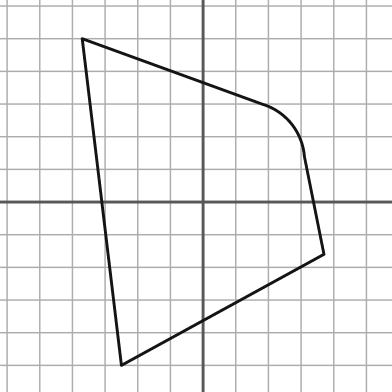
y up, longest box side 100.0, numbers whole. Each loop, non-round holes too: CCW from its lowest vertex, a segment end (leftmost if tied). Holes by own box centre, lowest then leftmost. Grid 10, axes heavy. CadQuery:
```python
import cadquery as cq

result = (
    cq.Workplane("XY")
    .moveTo(-25.0, -50.0)
    .lineTo(37.0, -16.0)
    .lineTo(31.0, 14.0)
    .threePointArc((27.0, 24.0), (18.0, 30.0))
    .lineTo(-37.0, 50.0)
    .close()
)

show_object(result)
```